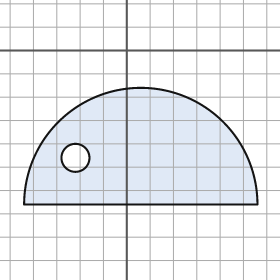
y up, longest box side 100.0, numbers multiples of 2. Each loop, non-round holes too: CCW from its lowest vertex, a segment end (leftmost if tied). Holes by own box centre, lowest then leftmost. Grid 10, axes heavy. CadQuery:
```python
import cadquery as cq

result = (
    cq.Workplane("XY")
    .moveTo(-44.0, -66.0)
    .lineTo(56.0, -66.0)
    .threePointArc((6.0, -16.0), (-44.0, -66.0))
    .close()
    .moveTo(-22.0, -46.0)
    .circle(6.0)
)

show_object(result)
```